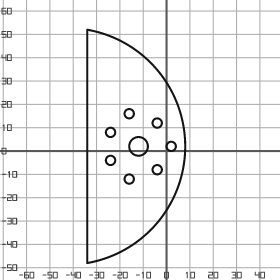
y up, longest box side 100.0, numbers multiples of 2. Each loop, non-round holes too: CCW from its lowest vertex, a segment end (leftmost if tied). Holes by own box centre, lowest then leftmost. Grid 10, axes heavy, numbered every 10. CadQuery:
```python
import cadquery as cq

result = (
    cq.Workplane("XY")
    .moveTo(-34.0, -48.0)
    .threePointArc((8.0, 2.0), (-34.0, 52.0))
    .close()
    .moveTo(-16.0, -12.0)
    .circle(2.0)
    .moveTo(-4.0, -8.0)
    .circle(2.0)
    .moveTo(-24.0, -4.0)
    .circle(2.0)
    .moveTo(-12.0, 2.0)
    .circle(4.0)
    .moveTo(2.0, 2.0)
    .circle(2.0)
    .moveTo(-24.0, 8.0)
    .circle(2.0)
    .moveTo(-4.0, 12.0)
    .circle(2.0)
    .moveTo(-16.0, 16.0)
    .circle(2.0)
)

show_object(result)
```